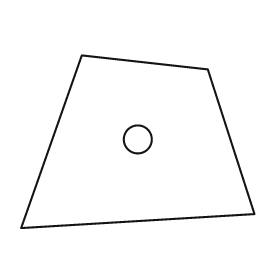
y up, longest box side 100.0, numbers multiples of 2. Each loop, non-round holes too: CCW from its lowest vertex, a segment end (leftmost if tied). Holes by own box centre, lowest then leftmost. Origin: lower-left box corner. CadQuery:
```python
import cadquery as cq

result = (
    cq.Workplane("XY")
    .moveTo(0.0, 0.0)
    .lineTo(100.0, 6.0)
    .lineTo(80.0, 68.0)
    .lineTo(26.0, 74.0)
    .close()
    .moveTo(50.0, 38.0)
    .circle(6.0)
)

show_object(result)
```